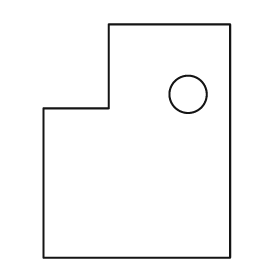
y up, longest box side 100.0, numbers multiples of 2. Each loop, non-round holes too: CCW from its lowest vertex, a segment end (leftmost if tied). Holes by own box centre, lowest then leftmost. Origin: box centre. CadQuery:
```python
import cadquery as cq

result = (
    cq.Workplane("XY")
    .moveTo(-40.0, -50.0)
    .lineTo(40.0, -50.0)
    .lineTo(40.0, 50.0)
    .lineTo(-12.0, 50.0)
    .lineTo(-12.0, 14.0)
    .lineTo(-40.0, 14.0)
    .close()
    .moveTo(22.0, 20.0)
    .circle(8.0)
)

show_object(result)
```